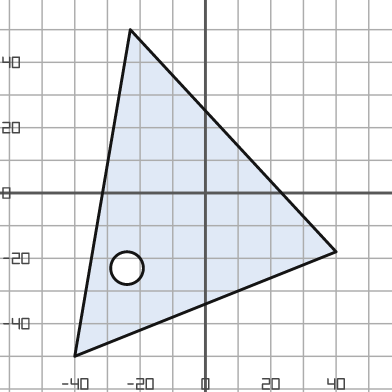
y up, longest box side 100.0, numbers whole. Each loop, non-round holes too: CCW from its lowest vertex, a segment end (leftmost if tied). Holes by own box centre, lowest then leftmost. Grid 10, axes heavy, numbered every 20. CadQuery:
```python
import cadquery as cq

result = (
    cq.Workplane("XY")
    .moveTo(-40.0, -50.0)
    .lineTo(40.0, -18.0)
    .lineTo(-23.0, 50.0)
    .close()
    .moveTo(-24.0, -23.0)
    .circle(5.0)
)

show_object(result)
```